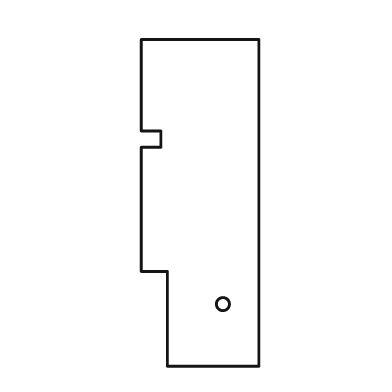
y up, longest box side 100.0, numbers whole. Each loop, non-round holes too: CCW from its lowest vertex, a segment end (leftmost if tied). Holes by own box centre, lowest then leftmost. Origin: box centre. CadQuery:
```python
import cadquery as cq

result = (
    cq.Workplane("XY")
    .moveTo(-10.0, -50.0)
    .lineTo(18.0, -50.0)
    .lineTo(18.0, 50.0)
    .lineTo(-18.0, 50.0)
    .lineTo(-18.0, 22.0)
    .lineTo(-12.0, 22.0)
    .lineTo(-12.0, 17.0)
    .lineTo(-18.0, 17.0)
    .lineTo(-18.0, -21.0)
    .lineTo(-10.0, -21.0)
    .close()
    .moveTo(7.0, -31.0)
    .circle(2.0)
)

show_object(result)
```